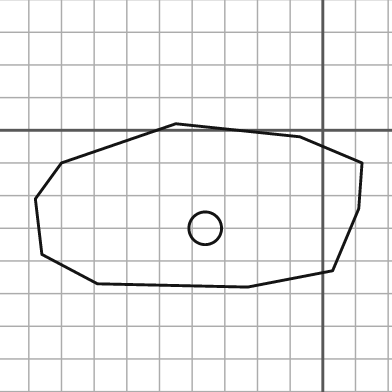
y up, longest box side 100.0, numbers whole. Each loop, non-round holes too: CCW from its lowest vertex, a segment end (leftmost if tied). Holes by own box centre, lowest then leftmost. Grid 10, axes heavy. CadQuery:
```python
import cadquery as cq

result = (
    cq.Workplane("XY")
    .moveTo(-23.0, -48.0)
    .lineTo(3.0, -43.0)
    .lineTo(11.0, -24.0)
    .lineTo(12.0, -10.0)
    .lineTo(-7.0, -2.0)
    .lineTo(-45.0, 2.0)
    .lineTo(-80.0, -10.0)
    .lineTo(-88.0, -21.0)
    .lineTo(-86.0, -38.0)
    .lineTo(-69.0, -47.0)
    .close()
    .moveTo(-36.0, -30.0)
    .circle(5.0)
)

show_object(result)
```